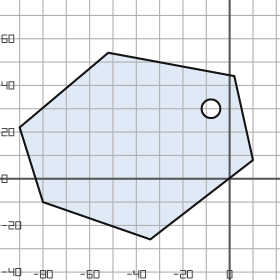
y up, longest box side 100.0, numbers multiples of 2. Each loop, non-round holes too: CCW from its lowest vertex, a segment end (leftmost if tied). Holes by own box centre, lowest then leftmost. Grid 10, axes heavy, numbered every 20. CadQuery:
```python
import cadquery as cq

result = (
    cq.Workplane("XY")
    .moveTo(-34.0, -26.0)
    .lineTo(10.0, 8.0)
    .lineTo(2.0, 44.0)
    .lineTo(-52.0, 54.0)
    .lineTo(-90.0, 22.0)
    .lineTo(-80.0, -10.0)
    .close()
    .moveTo(-8.0, 30.0)
    .circle(4.0)
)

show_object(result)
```